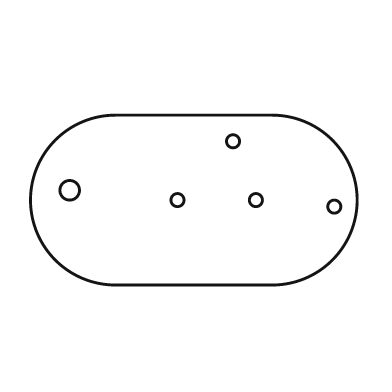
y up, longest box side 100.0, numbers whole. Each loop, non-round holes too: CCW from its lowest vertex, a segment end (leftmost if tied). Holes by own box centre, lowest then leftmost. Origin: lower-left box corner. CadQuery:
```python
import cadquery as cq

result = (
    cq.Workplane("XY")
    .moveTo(26.0, 0.0)
    .lineTo(74.0, 0.0)
    .threePointArc((100.0, 26.0), (74.0, 52.0))
    .lineTo(26.0, 52.0)
    .threePointArc((0.0, 26.0), (26.0, 0.0))
    .close()
    .moveTo(93.0, 24.0)
    .circle(2.0)
    .moveTo(45.0, 26.0)
    .circle(2.0)
    .moveTo(69.0, 26.0)
    .circle(2.0)
    .moveTo(12.0, 29.0)
    .circle(3.0)
    .moveTo(62.0, 44.0)
    .circle(2.0)
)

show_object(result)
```